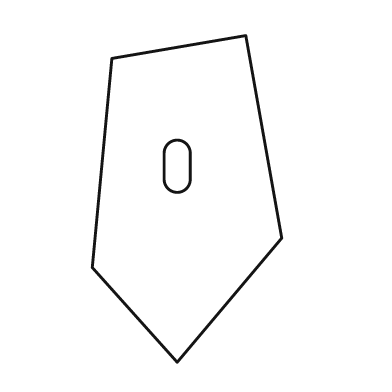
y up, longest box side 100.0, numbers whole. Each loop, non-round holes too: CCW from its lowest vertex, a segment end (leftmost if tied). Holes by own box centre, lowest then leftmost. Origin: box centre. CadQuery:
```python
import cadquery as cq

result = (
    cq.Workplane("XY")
    .moveTo(-3.0, -50.0)
    .lineTo(29.0, -12.0)
    .lineTo(18.0, 50.0)
    .lineTo(-23.0, 43.0)
    .lineTo(-29.0, -21.0)
    .close()
    .moveTo(-7.0, 6.0)
    .threePointArc((-3.0, 2.0), (1.0, 6.0))
    .lineTo(1.0, 14.0)
    .threePointArc((-3.0, 18.0), (-7.0, 14.0))
    .close()
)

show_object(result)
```